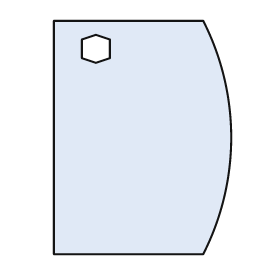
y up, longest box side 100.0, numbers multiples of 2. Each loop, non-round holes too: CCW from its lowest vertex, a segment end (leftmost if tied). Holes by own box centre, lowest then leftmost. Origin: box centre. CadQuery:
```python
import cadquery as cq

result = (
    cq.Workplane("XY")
    .moveTo(-38.0, -50.0)
    .lineTo(26.0, -50.0)
    .threePointArc((38.0, 0.0), (26.0, 50.0))
    .lineTo(-38.0, 50.0)
    .close()
    .moveTo(-20.0, 32.0)
    .lineTo(-14.0, 34.0)
    .lineTo(-14.0, 42.0)
    .lineTo(-20.0, 44.0)
    .lineTo(-26.0, 42.0)
    .lineTo(-26.0, 34.0)
    .close()
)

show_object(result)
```